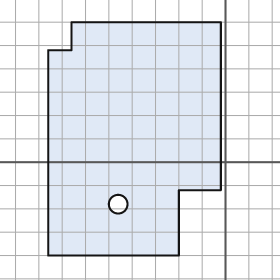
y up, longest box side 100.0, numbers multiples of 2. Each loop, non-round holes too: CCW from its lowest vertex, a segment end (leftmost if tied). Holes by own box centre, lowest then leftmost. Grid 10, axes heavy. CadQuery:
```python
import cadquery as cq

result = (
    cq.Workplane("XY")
    .moveTo(-76.0, -40.0)
    .lineTo(-20.0, -40.0)
    .lineTo(-20.0, -12.0)
    .lineTo(-2.0, -12.0)
    .lineTo(-2.0, 60.0)
    .lineTo(-66.0, 60.0)
    .lineTo(-66.0, 48.0)
    .lineTo(-76.0, 48.0)
    .close()
    .moveTo(-46.0, -18.0)
    .circle(4.0)
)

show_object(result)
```